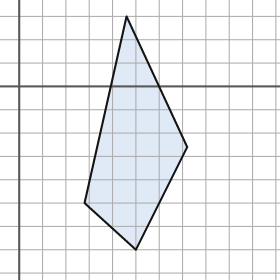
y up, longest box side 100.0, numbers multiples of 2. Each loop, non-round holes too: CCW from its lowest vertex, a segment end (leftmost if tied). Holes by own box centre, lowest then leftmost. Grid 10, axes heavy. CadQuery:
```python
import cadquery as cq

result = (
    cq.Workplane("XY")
    .moveTo(50.0, -70.0)
    .lineTo(72.0, -26.0)
    .lineTo(46.0, 30.0)
    .lineTo(28.0, -50.0)
    .close()
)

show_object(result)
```